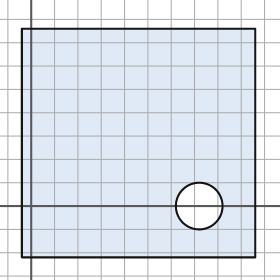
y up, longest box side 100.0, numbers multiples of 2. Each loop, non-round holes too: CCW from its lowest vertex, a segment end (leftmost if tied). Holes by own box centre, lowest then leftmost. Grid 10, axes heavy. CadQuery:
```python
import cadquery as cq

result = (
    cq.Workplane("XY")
    .moveTo(-4.0, -22.0)
    .lineTo(96.0, -22.0)
    .lineTo(96.0, 76.0)
    .lineTo(-4.0, 76.0)
    .close()
    .moveTo(72.0, 0.0)
    .circle(10.0)
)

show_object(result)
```